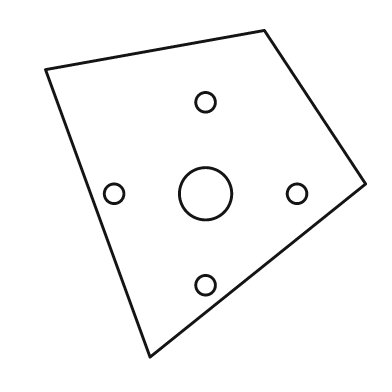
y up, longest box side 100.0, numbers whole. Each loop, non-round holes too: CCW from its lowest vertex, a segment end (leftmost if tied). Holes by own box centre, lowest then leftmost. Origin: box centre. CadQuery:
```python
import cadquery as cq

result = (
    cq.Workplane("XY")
    .moveTo(-17.0, -50.0)
    .lineTo(49.0, 3.0)
    .lineTo(18.0, 50.0)
    .lineTo(-49.0, 38.0)
    .close()
    .moveTo(0.0, -28.0)
    .circle(3.0)
    .moveTo(-28.0, 0.0)
    .circle(3.0)
    .moveTo(0.0, 0.0)
    .circle(8.0)
    .moveTo(28.0, 0.0)
    .circle(3.0)
    .moveTo(0.0, 28.0)
    .circle(3.0)
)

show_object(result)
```